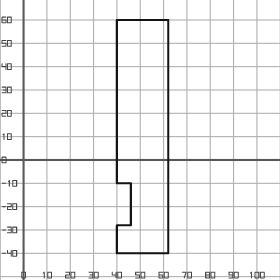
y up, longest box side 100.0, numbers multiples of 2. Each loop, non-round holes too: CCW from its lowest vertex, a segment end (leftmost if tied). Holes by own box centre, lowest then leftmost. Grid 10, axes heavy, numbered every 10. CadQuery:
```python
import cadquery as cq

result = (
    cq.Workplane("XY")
    .moveTo(40.0, -40.0)
    .lineTo(62.0, -40.0)
    .lineTo(62.0, 60.0)
    .lineTo(40.0, 60.0)
    .lineTo(40.0, -10.0)
    .lineTo(46.0, -10.0)
    .lineTo(46.0, -28.0)
    .lineTo(40.0, -28.0)
    .close()
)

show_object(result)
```